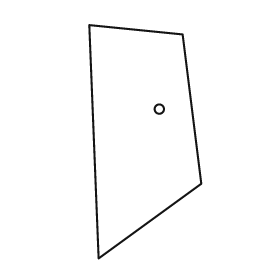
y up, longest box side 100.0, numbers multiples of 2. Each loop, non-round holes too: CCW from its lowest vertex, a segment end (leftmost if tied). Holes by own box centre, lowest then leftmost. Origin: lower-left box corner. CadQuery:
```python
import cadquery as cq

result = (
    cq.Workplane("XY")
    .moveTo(4.0, 0.0)
    .lineTo(48.0, 32.0)
    .lineTo(40.0, 96.0)
    .lineTo(0.0, 100.0)
    .close()
    .moveTo(30.0, 64.0)
    .circle(2.0)
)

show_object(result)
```